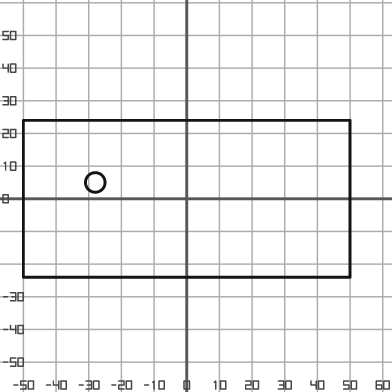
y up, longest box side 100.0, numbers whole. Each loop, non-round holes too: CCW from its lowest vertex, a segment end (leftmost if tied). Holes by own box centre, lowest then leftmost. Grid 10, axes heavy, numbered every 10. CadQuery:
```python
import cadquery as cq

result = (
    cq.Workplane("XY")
    .moveTo(-50.0, -24.0)
    .lineTo(50.0, -24.0)
    .lineTo(50.0, 24.0)
    .lineTo(-50.0, 24.0)
    .close()
    .moveTo(-28.0, 5.0)
    .circle(3.0)
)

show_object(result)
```